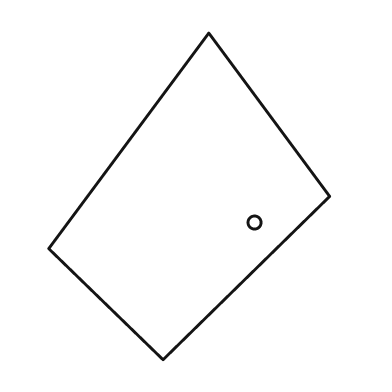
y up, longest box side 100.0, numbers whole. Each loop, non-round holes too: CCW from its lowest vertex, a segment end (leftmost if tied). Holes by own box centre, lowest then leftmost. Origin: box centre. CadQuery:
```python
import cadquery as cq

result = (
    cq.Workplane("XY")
    .moveTo(-8.0, -50.0)
    .lineTo(43.0, 0.0)
    .lineTo(6.0, 50.0)
    .lineTo(-43.0, -16.0)
    .close()
    .moveTo(20.0, -8.0)
    .circle(2.0)
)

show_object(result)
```